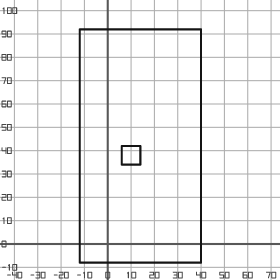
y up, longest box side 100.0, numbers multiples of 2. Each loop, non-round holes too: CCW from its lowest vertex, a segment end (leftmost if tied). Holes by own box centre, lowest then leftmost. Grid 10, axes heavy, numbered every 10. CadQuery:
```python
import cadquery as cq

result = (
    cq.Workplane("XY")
    .moveTo(-12.0, -8.0)
    .lineTo(40.0, -8.0)
    .lineTo(40.0, 92.0)
    .lineTo(-12.0, 92.0)
    .close()
    .moveTo(6.0, 34.0)
    .lineTo(14.0, 34.0)
    .lineTo(14.0, 42.0)
    .lineTo(6.0, 42.0)
    .close()
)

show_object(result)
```